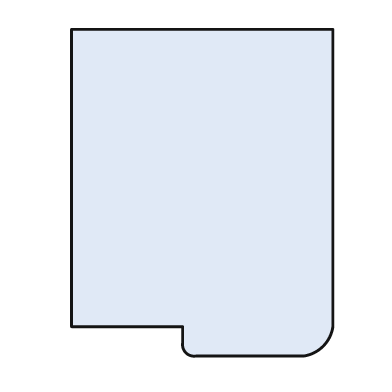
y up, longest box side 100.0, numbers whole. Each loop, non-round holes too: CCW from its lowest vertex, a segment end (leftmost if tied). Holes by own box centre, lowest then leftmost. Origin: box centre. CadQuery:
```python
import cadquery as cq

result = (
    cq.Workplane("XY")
    .moveTo(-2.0, -50.0)
    .lineTo(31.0, -50.0)
    .threePointArc((37.0, -47.0), (40.0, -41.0))
    .lineTo(40.0, 50.0)
    .lineTo(-40.0, 50.0)
    .lineTo(-40.0, -41.0)
    .lineTo(-6.0, -41.0)
    .lineTo(-6.0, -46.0)
    .threePointArc((-5.0, -49.0), (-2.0, -50.0))
    .close()
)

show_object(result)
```